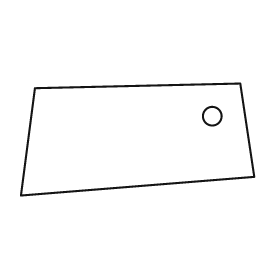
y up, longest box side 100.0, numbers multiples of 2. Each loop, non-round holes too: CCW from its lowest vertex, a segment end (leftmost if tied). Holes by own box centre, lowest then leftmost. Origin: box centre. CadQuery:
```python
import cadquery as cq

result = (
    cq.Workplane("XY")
    .moveTo(-50.0, -24.0)
    .lineTo(50.0, -16.0)
    .lineTo(44.0, 24.0)
    .lineTo(-44.0, 22.0)
    .close()
    .moveTo(32.0, 10.0)
    .circle(4.0)
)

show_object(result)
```